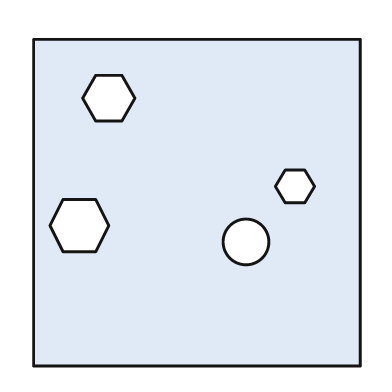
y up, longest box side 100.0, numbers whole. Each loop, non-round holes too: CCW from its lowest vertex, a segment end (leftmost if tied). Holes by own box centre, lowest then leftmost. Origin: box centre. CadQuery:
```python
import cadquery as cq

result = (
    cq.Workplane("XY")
    .moveTo(-50.0, -50.0)
    .lineTo(50.0, -50.0)
    .lineTo(50.0, 50.0)
    .lineTo(-50.0, 50.0)
    .close()
    .moveTo(15.0, -12.0)
    .circle(7.0)
    .moveTo(-41.0, -15.0)
    .lineTo(-31.0, -15.0)
    .lineTo(-27.0, -7.0)
    .lineTo(-31.0, 1.0)
    .lineTo(-41.0, 1.0)
    .lineTo(-45.0, -7.0)
    .close()
    .moveTo(27.0, 0.0)
    .lineTo(33.0, 0.0)
    .lineTo(36.0, 5.0)
    .lineTo(33.0, 10.0)
    .lineTo(27.0, 10.0)
    .lineTo(24.0, 5.0)
    .close()
    .moveTo(-31.0, 25.0)
    .lineTo(-23.0, 25.0)
    .lineTo(-19.0, 32.0)
    .lineTo(-23.0, 39.0)
    .lineTo(-31.0, 39.0)
    .lineTo(-35.0, 32.0)
    .close()
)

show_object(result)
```